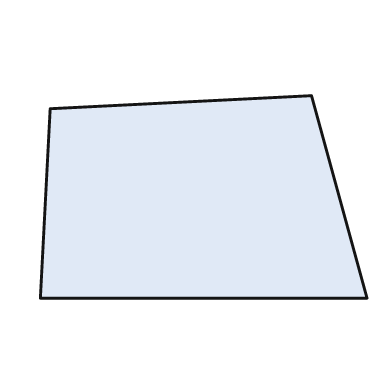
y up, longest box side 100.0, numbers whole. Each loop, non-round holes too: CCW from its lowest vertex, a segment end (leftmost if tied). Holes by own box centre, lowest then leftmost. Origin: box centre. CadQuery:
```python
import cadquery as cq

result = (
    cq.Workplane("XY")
    .moveTo(-50.0, -31.0)
    .lineTo(50.0, -31.0)
    .lineTo(33.0, 31.0)
    .lineTo(-47.0, 27.0)
    .close()
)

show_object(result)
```